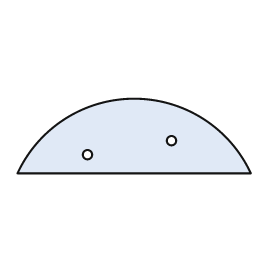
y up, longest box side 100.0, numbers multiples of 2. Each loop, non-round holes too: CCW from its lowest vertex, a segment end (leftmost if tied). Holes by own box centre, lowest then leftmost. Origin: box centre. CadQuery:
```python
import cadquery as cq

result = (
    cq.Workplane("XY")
    .moveTo(-50.0, -16.0)
    .lineTo(50.0, -16.0)
    .threePointArc((0.0, 16.0), (-50.0, -16.0))
    .close()
    .moveTo(-20.0, -8.0)
    .circle(2.0)
    .moveTo(16.0, -2.0)
    .circle(2.0)
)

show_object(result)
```